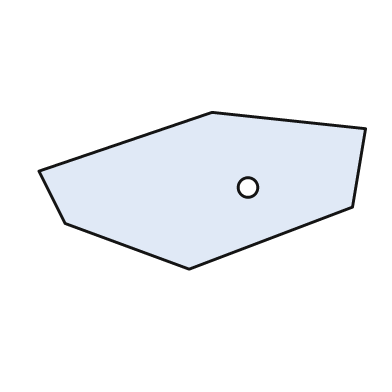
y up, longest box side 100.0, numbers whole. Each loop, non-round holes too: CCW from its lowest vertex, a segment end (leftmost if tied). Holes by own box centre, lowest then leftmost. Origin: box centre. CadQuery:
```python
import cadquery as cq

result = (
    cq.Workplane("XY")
    .moveTo(-4.0, -24.0)
    .lineTo(46.0, -5.0)
    .lineTo(50.0, 19.0)
    .lineTo(3.0, 24.0)
    .lineTo(-50.0, 6.0)
    .lineTo(-42.0, -10.0)
    .close()
    .moveTo(14.0, 1.0)
    .circle(3.0)
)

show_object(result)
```